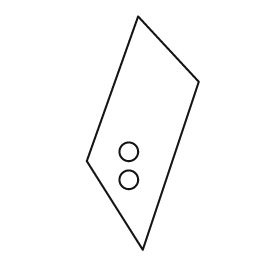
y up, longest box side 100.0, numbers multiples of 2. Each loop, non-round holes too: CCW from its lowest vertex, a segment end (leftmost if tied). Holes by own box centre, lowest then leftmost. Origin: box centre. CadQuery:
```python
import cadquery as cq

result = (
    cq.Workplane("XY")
    .moveTo(0.0, -50.0)
    .lineTo(24.0, 22.0)
    .lineTo(-2.0, 50.0)
    .lineTo(-24.0, -12.0)
    .close()
    .moveTo(-6.0, -20.0)
    .circle(4.0)
    .moveTo(-6.0, -8.0)
    .circle(4.0)
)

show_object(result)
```